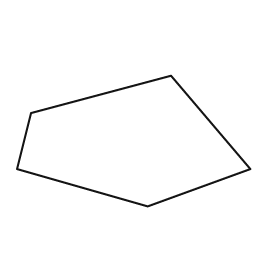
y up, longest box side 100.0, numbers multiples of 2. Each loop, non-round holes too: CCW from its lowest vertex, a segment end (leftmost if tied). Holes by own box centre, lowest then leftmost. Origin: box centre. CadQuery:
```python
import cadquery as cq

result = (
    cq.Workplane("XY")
    .moveTo(6.0, -28.0)
    .lineTo(50.0, -12.0)
    .lineTo(16.0, 28.0)
    .lineTo(-44.0, 12.0)
    .lineTo(-50.0, -12.0)
    .close()
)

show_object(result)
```